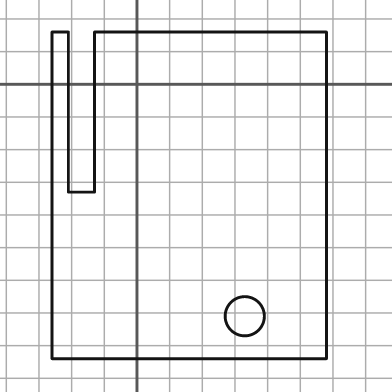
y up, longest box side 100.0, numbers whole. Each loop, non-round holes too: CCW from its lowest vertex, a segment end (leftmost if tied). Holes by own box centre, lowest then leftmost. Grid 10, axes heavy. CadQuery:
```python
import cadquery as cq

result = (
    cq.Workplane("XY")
    .moveTo(-26.0, -84.0)
    .lineTo(58.0, -84.0)
    .lineTo(58.0, 16.0)
    .lineTo(-13.0, 16.0)
    .lineTo(-13.0, -33.0)
    .lineTo(-21.0, -33.0)
    .lineTo(-21.0, 16.0)
    .lineTo(-26.0, 16.0)
    .close()
    .moveTo(33.0, -71.0)
    .circle(6.0)
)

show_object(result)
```